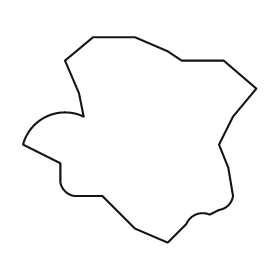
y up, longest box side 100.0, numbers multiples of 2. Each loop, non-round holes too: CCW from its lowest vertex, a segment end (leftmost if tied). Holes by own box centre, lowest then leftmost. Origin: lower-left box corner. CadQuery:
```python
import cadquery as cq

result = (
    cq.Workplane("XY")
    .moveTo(62.0, 0.0)
    .lineTo(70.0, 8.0)
    .threePointArc((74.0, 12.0), (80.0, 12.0))
    .lineTo(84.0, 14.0)
    .threePointArc((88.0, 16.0), (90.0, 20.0))
    .lineTo(88.0, 32.0)
    .lineTo(84.0, 42.0)
    .lineTo(90.0, 54.0)
    .lineTo(100.0, 66.0)
    .lineTo(86.0, 78.0)
    .lineTo(68.0, 78.0)
    .lineTo(62.0, 82.0)
    .lineTo(48.0, 88.0)
    .lineTo(30.0, 88.0)
    .lineTo(18.0, 78.0)
    .lineTo(24.0, 64.0)
    .lineTo(26.0, 54.0)
    .threePointArc((10.0, 54.0), (0.0, 42.0))
    .lineTo(16.0, 34.0)
    .lineTo(16.0, 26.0)
    .threePointArc((18.0, 22.0), (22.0, 20.0))
    .lineTo(34.0, 20.0)
    .lineTo(48.0, 6.0)
    .close()
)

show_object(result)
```